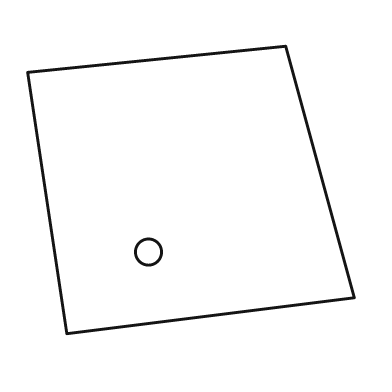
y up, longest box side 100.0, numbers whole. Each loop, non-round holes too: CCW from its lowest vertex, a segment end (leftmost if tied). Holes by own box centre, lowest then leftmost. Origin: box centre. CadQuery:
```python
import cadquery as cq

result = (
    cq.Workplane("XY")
    .moveTo(-38.0, -44.0)
    .lineTo(50.0, -33.0)
    .lineTo(29.0, 44.0)
    .lineTo(-50.0, 36.0)
    .close()
    .moveTo(-13.0, -19.0)
    .circle(4.0)
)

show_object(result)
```